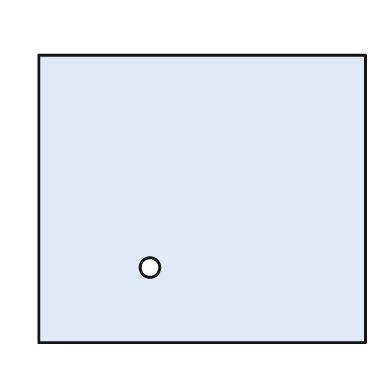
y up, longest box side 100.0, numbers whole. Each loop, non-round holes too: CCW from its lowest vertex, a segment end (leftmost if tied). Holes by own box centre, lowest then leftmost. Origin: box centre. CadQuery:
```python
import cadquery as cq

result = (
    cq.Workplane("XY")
    .moveTo(-50.0, -44.0)
    .lineTo(50.0, -44.0)
    .lineTo(50.0, 44.0)
    .lineTo(-50.0, 44.0)
    .close()
    .moveTo(-16.0, -21.0)
    .circle(3.0)
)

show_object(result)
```